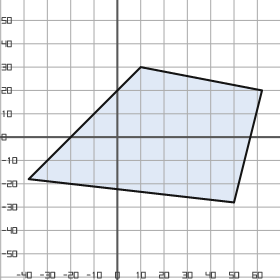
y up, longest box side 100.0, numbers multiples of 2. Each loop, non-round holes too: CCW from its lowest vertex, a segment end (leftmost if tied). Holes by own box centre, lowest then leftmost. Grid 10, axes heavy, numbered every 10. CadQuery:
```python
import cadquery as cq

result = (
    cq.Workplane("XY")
    .moveTo(50.0, -28.0)
    .lineTo(62.0, 20.0)
    .lineTo(10.0, 30.0)
    .lineTo(-38.0, -18.0)
    .close()
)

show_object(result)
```